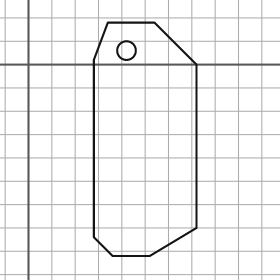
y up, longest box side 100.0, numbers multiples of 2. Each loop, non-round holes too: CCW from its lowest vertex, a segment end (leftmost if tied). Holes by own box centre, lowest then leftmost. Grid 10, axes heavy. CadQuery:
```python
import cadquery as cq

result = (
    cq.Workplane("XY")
    .moveTo(36.0, -82.0)
    .lineTo(52.0, -82.0)
    .lineTo(72.0, -70.0)
    .lineTo(72.0, 0.0)
    .lineTo(54.0, 18.0)
    .lineTo(34.0, 18.0)
    .lineTo(28.0, 2.0)
    .lineTo(28.0, -74.0)
    .close()
    .moveTo(42.0, 6.0)
    .circle(4.0)
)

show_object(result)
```